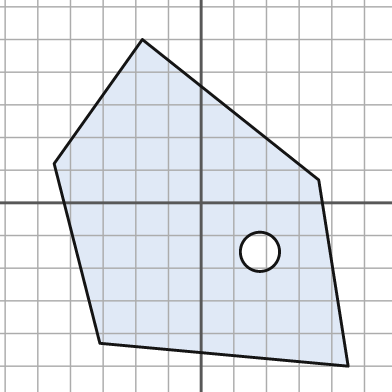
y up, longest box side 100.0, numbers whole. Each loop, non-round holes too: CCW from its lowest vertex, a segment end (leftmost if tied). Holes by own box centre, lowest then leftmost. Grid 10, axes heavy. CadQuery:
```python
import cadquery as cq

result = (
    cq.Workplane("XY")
    .moveTo(45.0, -50.0)
    .lineTo(36.0, 7.0)
    .lineTo(-18.0, 50.0)
    .lineTo(-45.0, 12.0)
    .lineTo(-31.0, -43.0)
    .close()
    .moveTo(18.0, -15.0)
    .circle(6.0)
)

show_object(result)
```